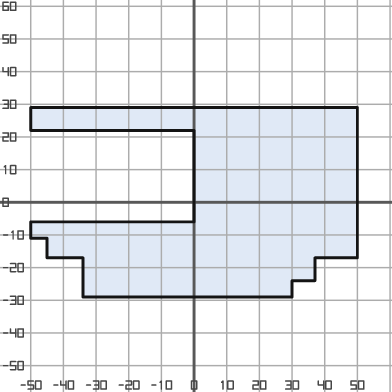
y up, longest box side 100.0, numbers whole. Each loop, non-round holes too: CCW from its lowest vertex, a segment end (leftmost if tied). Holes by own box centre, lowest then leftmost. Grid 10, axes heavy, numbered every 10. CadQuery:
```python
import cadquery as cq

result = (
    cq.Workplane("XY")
    .moveTo(-34.0, -29.0)
    .lineTo(30.0, -29.0)
    .lineTo(30.0, -24.0)
    .lineTo(37.0, -24.0)
    .lineTo(37.0, -17.0)
    .lineTo(50.0, -17.0)
    .lineTo(50.0, 29.0)
    .lineTo(-50.0, 29.0)
    .lineTo(-50.0, 22.0)
    .lineTo(0.0, 22.0)
    .lineTo(0.0, -6.0)
    .lineTo(-50.0, -6.0)
    .lineTo(-50.0, -11.0)
    .lineTo(-45.0, -11.0)
    .lineTo(-45.0, -17.0)
    .lineTo(-34.0, -17.0)
    .close()
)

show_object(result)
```